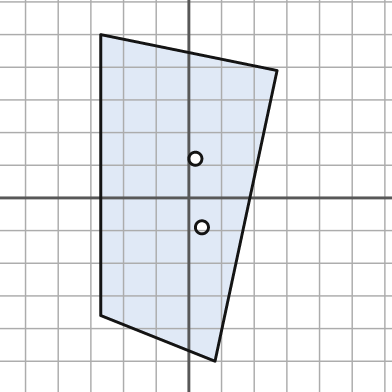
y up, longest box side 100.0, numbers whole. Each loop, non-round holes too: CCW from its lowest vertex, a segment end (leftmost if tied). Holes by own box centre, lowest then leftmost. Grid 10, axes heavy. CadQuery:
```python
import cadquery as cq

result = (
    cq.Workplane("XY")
    .moveTo(8.0, -50.0)
    .lineTo(27.0, 39.0)
    .lineTo(-27.0, 50.0)
    .lineTo(-27.0, -36.0)
    .close()
    .moveTo(4.0, -9.0)
    .circle(2.0)
    .moveTo(2.0, 12.0)
    .circle(2.0)
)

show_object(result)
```